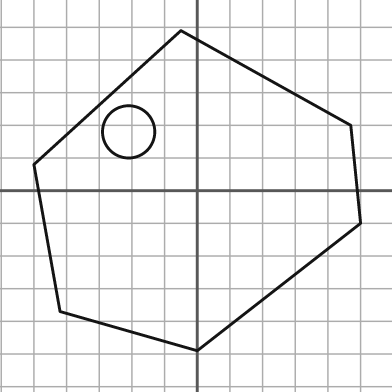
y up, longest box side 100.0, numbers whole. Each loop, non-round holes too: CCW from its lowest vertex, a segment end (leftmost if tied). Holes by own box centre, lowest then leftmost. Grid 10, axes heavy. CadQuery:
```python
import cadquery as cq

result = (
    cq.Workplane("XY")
    .moveTo(0.0, -49.0)
    .lineTo(50.0, -10.0)
    .lineTo(47.0, 20.0)
    .lineTo(-5.0, 49.0)
    .lineTo(-50.0, 8.0)
    .lineTo(-42.0, -37.0)
    .close()
    .moveTo(-21.0, 18.0)
    .circle(8.0)
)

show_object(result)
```